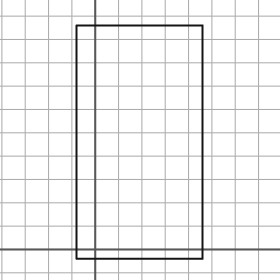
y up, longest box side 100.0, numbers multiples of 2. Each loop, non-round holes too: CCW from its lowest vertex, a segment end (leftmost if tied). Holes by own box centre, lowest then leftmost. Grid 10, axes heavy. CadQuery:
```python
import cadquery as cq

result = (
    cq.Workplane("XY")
    .moveTo(-8.0, -4.0)
    .lineTo(46.0, -4.0)
    .lineTo(46.0, 96.0)
    .lineTo(-8.0, 96.0)
    .close()
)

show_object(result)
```